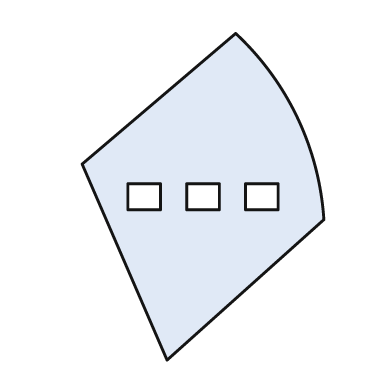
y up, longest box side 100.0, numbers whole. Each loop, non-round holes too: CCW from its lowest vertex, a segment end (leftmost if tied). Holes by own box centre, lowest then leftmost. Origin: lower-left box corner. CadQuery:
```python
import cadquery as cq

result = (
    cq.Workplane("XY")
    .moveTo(26.0, 0.0)
    .lineTo(74.0, 43.0)
    .threePointArc((66.0, 74.0), (47.0, 100.0))
    .lineTo(0.0, 60.0)
    .close()
    .moveTo(14.0, 46.0)
    .lineTo(24.0, 46.0)
    .lineTo(24.0, 54.0)
    .lineTo(14.0, 54.0)
    .close()
    .moveTo(32.0, 46.0)
    .lineTo(42.0, 46.0)
    .lineTo(42.0, 54.0)
    .lineTo(32.0, 54.0)
    .close()
    .moveTo(50.0, 46.0)
    .lineTo(60.0, 46.0)
    .lineTo(60.0, 54.0)
    .lineTo(50.0, 54.0)
    .close()
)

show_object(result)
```